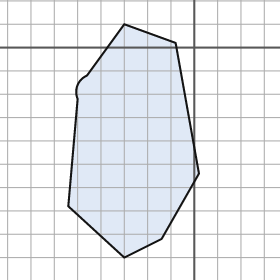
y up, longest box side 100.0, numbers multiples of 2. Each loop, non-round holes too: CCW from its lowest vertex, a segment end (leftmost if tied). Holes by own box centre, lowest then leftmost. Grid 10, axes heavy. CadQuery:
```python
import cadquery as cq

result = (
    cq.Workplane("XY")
    .moveTo(-30.0, -90.0)
    .lineTo(-14.0, -82.0)
    .lineTo(2.0, -54.0)
    .lineTo(-8.0, 2.0)
    .lineTo(-30.0, 10.0)
    .lineTo(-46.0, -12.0)
    .threePointArc((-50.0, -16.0), (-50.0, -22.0))
    .lineTo(-54.0, -68.0)
    .close()
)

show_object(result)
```